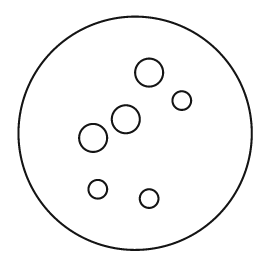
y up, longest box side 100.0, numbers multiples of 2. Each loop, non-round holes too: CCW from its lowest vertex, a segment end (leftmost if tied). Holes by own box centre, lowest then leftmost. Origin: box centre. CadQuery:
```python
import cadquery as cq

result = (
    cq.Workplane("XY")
    .moveTo(0.0, 0.0)
    .circle(50.0)
    .moveTo(6.0, -28.0)
    .circle(4.0)
    .moveTo(-16.0, -24.0)
    .circle(4.0)
    .moveTo(-18.0, -2.0)
    .circle(6.0)
    .moveTo(-4.0, 6.0)
    .circle(6.0)
    .moveTo(20.0, 14.0)
    .circle(4.0)
    .moveTo(6.0, 26.0)
    .circle(6.0)
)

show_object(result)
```